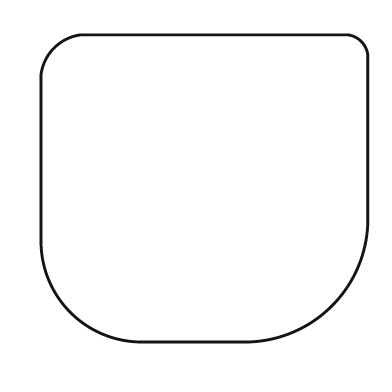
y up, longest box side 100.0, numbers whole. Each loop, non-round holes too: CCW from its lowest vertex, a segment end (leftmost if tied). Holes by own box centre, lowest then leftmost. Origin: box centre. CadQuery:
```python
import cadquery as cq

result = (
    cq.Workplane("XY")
    .moveTo(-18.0, -47.0)
    .lineTo(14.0, -47.0)
    .threePointArc((39.0, -36.0), (50.0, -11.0))
    .lineTo(50.0, 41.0)
    .threePointArc((48.0, 45.0), (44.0, 47.0))
    .lineTo(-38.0, 47.0)
    .threePointArc((-46.0, 43.0), (-50.0, 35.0))
    .lineTo(-50.0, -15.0)
    .threePointArc((-41.0, -38.0), (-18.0, -47.0))
    .close()
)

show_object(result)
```